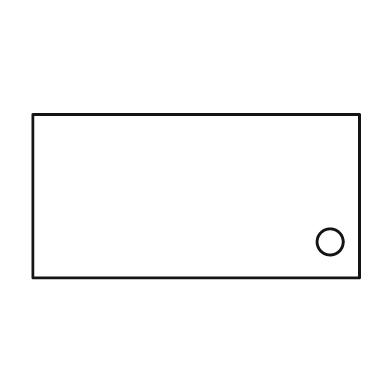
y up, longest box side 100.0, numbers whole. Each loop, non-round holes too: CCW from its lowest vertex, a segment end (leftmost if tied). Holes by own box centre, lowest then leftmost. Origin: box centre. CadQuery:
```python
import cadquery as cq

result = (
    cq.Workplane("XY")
    .moveTo(-50.0, -25.0)
    .lineTo(50.0, -25.0)
    .lineTo(50.0, 25.0)
    .lineTo(-50.0, 25.0)
    .close()
    .moveTo(41.0, -14.0)
    .circle(4.0)
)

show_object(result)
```